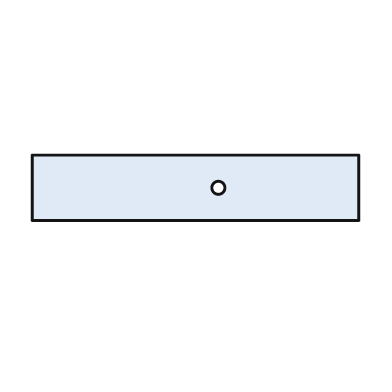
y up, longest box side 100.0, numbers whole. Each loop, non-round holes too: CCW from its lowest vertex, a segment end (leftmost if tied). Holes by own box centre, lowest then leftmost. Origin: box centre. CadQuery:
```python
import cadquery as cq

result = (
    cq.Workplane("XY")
    .moveTo(-50.0, -10.0)
    .lineTo(50.0, -10.0)
    .lineTo(50.0, 10.0)
    .lineTo(-50.0, 10.0)
    .close()
    .moveTo(7.0, 0.0)
    .circle(2.0)
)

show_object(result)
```